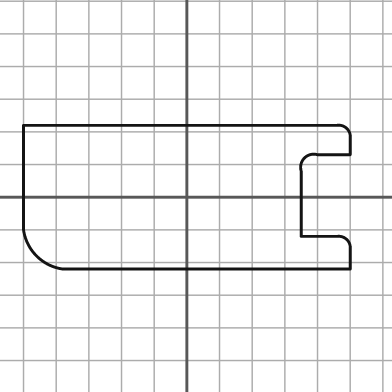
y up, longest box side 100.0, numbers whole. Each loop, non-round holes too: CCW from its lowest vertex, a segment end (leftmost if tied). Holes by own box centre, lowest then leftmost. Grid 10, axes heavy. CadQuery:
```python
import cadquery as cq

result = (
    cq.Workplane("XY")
    .moveTo(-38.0, -22.0)
    .lineTo(50.0, -22.0)
    .lineTo(50.0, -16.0)
    .threePointArc((49.0, -13.0), (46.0, -12.0))
    .lineTo(35.0, -12.0)
    .lineTo(35.0, 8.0)
    .threePointArc((36.0, 12.0), (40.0, 13.0))
    .lineTo(50.0, 13.0)
    .lineTo(50.0, 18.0)
    .threePointArc((49.0, 21.0), (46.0, 22.0))
    .lineTo(-50.0, 22.0)
    .lineTo(-50.0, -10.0)
    .threePointArc((-46.0, -18.0), (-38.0, -22.0))
    .close()
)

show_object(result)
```